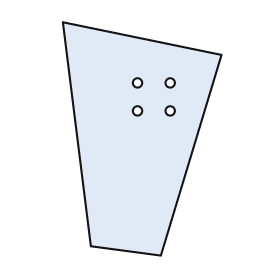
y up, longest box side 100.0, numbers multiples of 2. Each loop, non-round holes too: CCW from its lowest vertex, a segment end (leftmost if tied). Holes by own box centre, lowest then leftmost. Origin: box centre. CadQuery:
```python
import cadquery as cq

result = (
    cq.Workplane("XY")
    .moveTo(8.0, -50.0)
    .lineTo(34.0, 36.0)
    .lineTo(-34.0, 50.0)
    .lineTo(-22.0, -46.0)
    .close()
    .moveTo(-2.0, 12.0)
    .circle(2.0)
    .moveTo(12.0, 12.0)
    .circle(2.0)
    .moveTo(-2.0, 24.0)
    .circle(2.0)
    .moveTo(12.0, 24.0)
    .circle(2.0)
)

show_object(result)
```